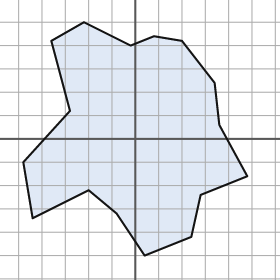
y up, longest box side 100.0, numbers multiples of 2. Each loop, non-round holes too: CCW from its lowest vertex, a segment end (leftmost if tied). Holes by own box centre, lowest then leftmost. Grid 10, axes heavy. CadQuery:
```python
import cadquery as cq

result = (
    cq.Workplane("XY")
    .moveTo(4.0, -50.0)
    .lineTo(24.0, -42.0)
    .lineTo(28.0, -24.0)
    .lineTo(48.0, -16.0)
    .lineTo(36.0, 6.0)
    .lineTo(34.0, 24.0)
    .lineTo(20.0, 42.0)
    .lineTo(8.0, 44.0)
    .lineTo(-2.0, 40.0)
    .lineTo(-22.0, 50.0)
    .lineTo(-36.0, 42.0)
    .lineTo(-28.0, 12.0)
    .lineTo(-48.0, -10.0)
    .lineTo(-44.0, -34.0)
    .lineTo(-20.0, -22.0)
    .lineTo(-8.0, -32.0)
    .close()
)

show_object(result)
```